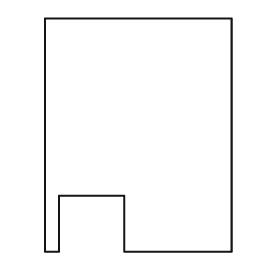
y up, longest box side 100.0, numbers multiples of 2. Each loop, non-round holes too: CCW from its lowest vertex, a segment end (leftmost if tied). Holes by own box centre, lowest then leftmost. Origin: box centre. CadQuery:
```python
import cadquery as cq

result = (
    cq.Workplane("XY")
    .moveTo(-40.0, -50.0)
    .lineTo(-34.0, -50.0)
    .lineTo(-34.0, -26.0)
    .lineTo(-6.0, -26.0)
    .lineTo(-6.0, -50.0)
    .lineTo(40.0, -50.0)
    .lineTo(40.0, 50.0)
    .lineTo(-40.0, 50.0)
    .close()
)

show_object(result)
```